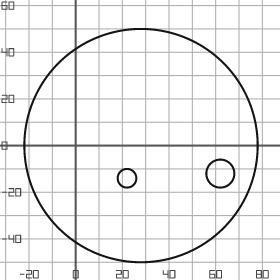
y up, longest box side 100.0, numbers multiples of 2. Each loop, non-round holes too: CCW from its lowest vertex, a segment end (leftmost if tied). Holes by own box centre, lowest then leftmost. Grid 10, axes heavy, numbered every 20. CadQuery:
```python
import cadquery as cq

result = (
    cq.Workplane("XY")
    .moveTo(28.0, 0.0)
    .circle(50.0)
    .moveTo(22.0, -14.0)
    .circle(4.0)
    .moveTo(62.0, -12.0)
    .circle(6.0)
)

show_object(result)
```